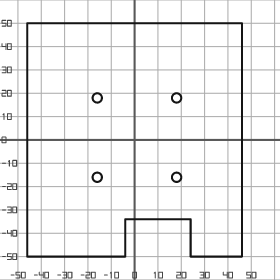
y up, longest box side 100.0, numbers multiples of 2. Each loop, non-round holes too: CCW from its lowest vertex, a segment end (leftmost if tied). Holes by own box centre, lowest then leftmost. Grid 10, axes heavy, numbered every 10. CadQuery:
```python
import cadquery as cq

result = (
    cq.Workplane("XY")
    .moveTo(-46.0, -50.0)
    .lineTo(-4.0, -50.0)
    .lineTo(-4.0, -34.0)
    .lineTo(24.0, -34.0)
    .lineTo(24.0, -50.0)
    .lineTo(46.0, -50.0)
    .lineTo(46.0, 50.0)
    .lineTo(-46.0, 50.0)
    .close()
    .moveTo(-16.0, -16.0)
    .circle(2.0)
    .moveTo(18.0, -16.0)
    .circle(2.0)
    .moveTo(-16.0, 18.0)
    .circle(2.0)
    .moveTo(18.0, 18.0)
    .circle(2.0)
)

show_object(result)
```